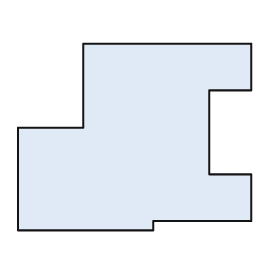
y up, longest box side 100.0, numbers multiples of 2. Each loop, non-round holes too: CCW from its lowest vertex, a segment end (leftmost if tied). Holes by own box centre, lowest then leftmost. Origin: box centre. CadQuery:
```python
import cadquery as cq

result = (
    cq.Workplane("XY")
    .moveTo(-50.0, -40.0)
    .lineTo(8.0, -40.0)
    .lineTo(8.0, -36.0)
    .lineTo(50.0, -36.0)
    .lineTo(50.0, -16.0)
    .lineTo(32.0, -16.0)
    .lineTo(32.0, 20.0)
    .lineTo(50.0, 20.0)
    .lineTo(50.0, 40.0)
    .lineTo(-22.0, 40.0)
    .lineTo(-22.0, 4.0)
    .lineTo(-50.0, 4.0)
    .close()
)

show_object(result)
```